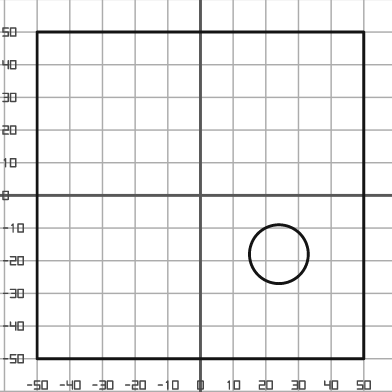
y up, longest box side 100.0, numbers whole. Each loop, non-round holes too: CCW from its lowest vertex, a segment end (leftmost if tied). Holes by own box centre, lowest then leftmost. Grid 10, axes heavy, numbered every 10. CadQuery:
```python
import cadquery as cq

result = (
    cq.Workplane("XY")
    .moveTo(-50.0, -50.0)
    .lineTo(50.0, -50.0)
    .lineTo(50.0, 50.0)
    .lineTo(-50.0, 50.0)
    .close()
    .moveTo(24.0, -18.0)
    .circle(9.0)
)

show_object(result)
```